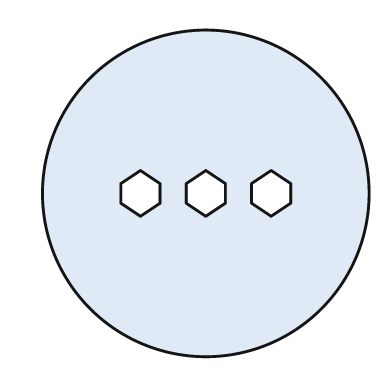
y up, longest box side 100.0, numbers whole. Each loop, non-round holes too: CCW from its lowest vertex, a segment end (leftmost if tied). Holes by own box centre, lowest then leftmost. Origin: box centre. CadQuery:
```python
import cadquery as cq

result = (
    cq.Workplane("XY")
    .moveTo(0.0, 0.0)
    .circle(50.0)
    .moveTo(-20.0, -7.0)
    .lineTo(-14.0, -3.0)
    .lineTo(-14.0, 3.0)
    .lineTo(-20.0, 7.0)
    .lineTo(-26.0, 3.0)
    .lineTo(-26.0, -3.0)
    .close()
    .moveTo(0.0, -7.0)
    .lineTo(6.0, -3.0)
    .lineTo(6.0, 3.0)
    .lineTo(0.0, 7.0)
    .lineTo(-6.0, 3.0)
    .lineTo(-6.0, -3.0)
    .close()
    .moveTo(20.0, -7.0)
    .lineTo(26.0, -3.0)
    .lineTo(26.0, 3.0)
    .lineTo(20.0, 7.0)
    .lineTo(14.0, 3.0)
    .lineTo(14.0, -3.0)
    .close()
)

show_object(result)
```